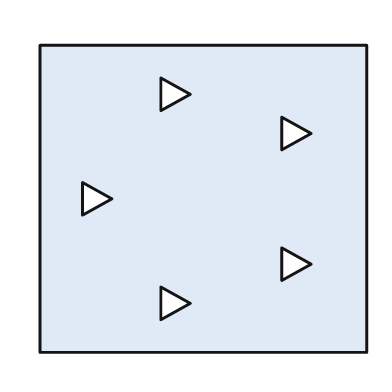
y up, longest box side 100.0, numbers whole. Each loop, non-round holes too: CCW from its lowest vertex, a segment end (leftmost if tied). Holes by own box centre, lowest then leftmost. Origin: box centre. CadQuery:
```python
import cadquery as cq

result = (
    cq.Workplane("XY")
    .moveTo(-50.0, -47.0)
    .lineTo(50.0, -47.0)
    .lineTo(50.0, 47.0)
    .lineTo(-50.0, 47.0)
    .close()
    .moveTo(-13.0, -37.0)
    .lineTo(-4.0, -32.0)
    .lineTo(-13.0, -27.0)
    .close()
    .moveTo(24.0, -25.0)
    .lineTo(33.0, -20.0)
    .lineTo(24.0, -15.0)
    .close()
    .moveTo(-37.0, -5.0)
    .lineTo(-28.0, 0.0)
    .lineTo(-37.0, 5.0)
    .close()
    .moveTo(24.0, 15.0)
    .lineTo(33.0, 20.0)
    .lineTo(24.0, 25.0)
    .close()
    .moveTo(-13.0, 27.0)
    .lineTo(-4.0, 32.0)
    .lineTo(-13.0, 37.0)
    .close()
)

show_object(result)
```